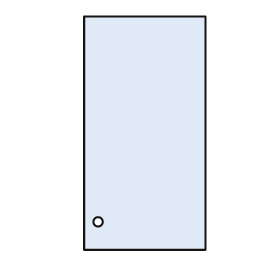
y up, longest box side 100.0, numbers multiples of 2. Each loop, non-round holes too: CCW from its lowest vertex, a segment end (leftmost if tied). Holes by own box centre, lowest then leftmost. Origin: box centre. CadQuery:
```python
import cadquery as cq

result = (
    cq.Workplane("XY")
    .moveTo(-26.0, -50.0)
    .lineTo(26.0, -50.0)
    .lineTo(26.0, 50.0)
    .lineTo(-26.0, 50.0)
    .close()
    .moveTo(-20.0, -38.0)
    .circle(2.0)
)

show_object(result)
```